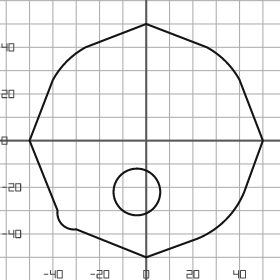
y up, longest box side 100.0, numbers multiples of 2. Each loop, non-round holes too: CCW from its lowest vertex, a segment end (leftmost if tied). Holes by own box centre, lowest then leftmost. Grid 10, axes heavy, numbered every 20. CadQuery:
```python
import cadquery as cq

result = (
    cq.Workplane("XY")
    .moveTo(0.0, -50.0)
    .lineTo(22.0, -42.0)
    .threePointArc((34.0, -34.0), (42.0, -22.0))
    .lineTo(50.0, 0.0)
    .lineTo(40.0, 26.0)
    .threePointArc((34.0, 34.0), (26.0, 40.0))
    .lineTo(0.0, 50.0)
    .lineTo(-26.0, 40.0)
    .threePointArc((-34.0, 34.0), (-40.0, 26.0))
    .lineTo(-50.0, 0.0)
    .lineTo(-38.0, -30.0)
    .threePointArc((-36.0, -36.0), (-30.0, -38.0))
    .close()
    .moveTo(-4.0, -22.0)
    .circle(10.0)
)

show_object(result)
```